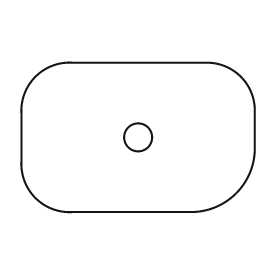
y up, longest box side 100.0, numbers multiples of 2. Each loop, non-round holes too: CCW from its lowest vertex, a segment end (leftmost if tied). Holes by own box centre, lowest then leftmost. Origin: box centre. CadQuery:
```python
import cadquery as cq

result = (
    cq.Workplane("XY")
    .moveTo(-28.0, -32.0)
    .lineTo(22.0, -32.0)
    .threePointArc((42.0, -24.0), (50.0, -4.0))
    .lineTo(50.0, 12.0)
    .threePointArc((44.0, 26.0), (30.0, 32.0))
    .lineTo(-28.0, 32.0)
    .threePointArc((-44.0, 26.0), (-50.0, 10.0))
    .lineTo(-50.0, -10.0)
    .threePointArc((-44.0, -26.0), (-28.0, -32.0))
    .close()
    .moveTo(0.0, 0.0)
    .circle(6.0)
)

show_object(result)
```